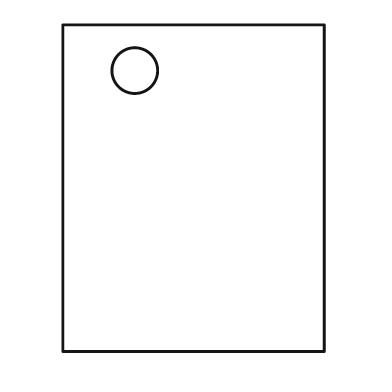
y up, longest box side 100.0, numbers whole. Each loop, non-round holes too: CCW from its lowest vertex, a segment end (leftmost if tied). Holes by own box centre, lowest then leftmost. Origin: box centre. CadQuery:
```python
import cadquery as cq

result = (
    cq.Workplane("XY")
    .moveTo(-40.0, -50.0)
    .lineTo(40.0, -50.0)
    .lineTo(40.0, 50.0)
    .lineTo(-40.0, 50.0)
    .close()
    .moveTo(-18.0, 36.0)
    .circle(7.0)
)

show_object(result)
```